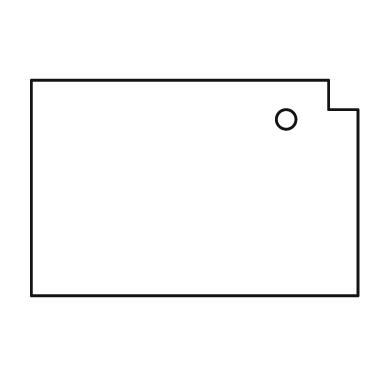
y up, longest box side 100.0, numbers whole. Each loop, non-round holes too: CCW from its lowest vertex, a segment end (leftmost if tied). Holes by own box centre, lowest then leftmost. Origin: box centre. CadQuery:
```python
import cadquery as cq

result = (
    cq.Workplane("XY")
    .moveTo(-50.0, -33.0)
    .lineTo(50.0, -33.0)
    .lineTo(50.0, 24.0)
    .lineTo(41.0, 24.0)
    .lineTo(41.0, 33.0)
    .lineTo(-50.0, 33.0)
    .close()
    .moveTo(28.0, 21.0)
    .circle(3.0)
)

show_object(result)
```